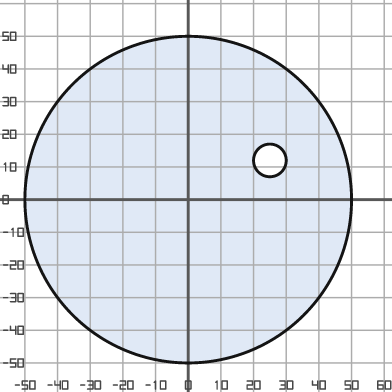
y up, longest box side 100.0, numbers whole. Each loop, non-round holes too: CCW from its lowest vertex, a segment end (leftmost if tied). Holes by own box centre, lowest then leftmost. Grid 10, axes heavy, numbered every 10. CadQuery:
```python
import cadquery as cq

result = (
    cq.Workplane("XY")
    .moveTo(0.0, 0.0)
    .circle(50.0)
    .moveTo(25.0, 12.0)
    .circle(5.0)
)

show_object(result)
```